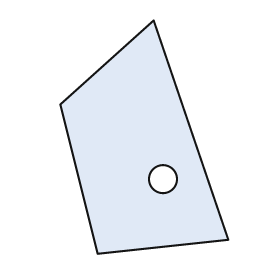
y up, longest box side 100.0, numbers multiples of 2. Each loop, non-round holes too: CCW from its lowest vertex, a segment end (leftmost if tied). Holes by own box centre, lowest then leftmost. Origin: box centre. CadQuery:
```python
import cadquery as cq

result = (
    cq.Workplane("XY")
    .moveTo(-20.0, -50.0)
    .lineTo(36.0, -44.0)
    .lineTo(4.0, 50.0)
    .lineTo(-36.0, 14.0)
    .close()
    .moveTo(8.0, -18.0)
    .circle(6.0)
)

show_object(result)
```